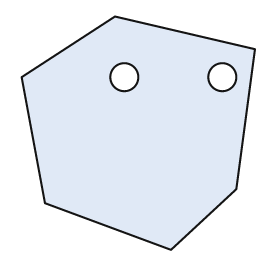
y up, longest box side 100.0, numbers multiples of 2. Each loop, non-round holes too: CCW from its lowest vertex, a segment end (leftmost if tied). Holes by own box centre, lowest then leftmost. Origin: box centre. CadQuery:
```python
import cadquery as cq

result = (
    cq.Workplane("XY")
    .moveTo(14.0, -50.0)
    .lineTo(42.0, -24.0)
    .lineTo(50.0, 36.0)
    .lineTo(-10.0, 50.0)
    .lineTo(-50.0, 24.0)
    .lineTo(-40.0, -30.0)
    .close()
    .moveTo(-6.0, 24.0)
    .circle(6.0)
    .moveTo(36.0, 24.0)
    .circle(6.0)
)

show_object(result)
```